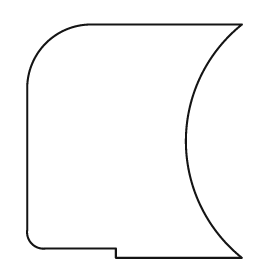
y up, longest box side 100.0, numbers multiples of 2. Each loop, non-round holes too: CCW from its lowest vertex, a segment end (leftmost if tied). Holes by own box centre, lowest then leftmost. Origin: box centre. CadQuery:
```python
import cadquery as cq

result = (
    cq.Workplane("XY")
    .moveTo(-8.0, -50.0)
    .lineTo(46.0, -50.0)
    .threePointArc((22.0, 0.0), (46.0, 50.0))
    .lineTo(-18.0, 50.0)
    .threePointArc((-38.0, 42.0), (-46.0, 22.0))
    .lineTo(-46.0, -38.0)
    .threePointArc((-44.0, -44.0), (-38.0, -46.0))
    .lineTo(-8.0, -46.0)
    .close()
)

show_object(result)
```